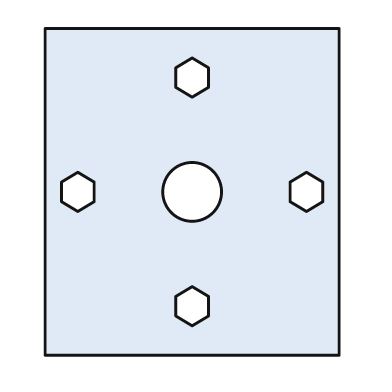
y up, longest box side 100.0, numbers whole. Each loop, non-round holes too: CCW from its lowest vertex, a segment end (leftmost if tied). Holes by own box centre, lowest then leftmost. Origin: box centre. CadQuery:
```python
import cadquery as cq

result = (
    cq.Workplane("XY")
    .moveTo(-45.0, -50.0)
    .lineTo(45.0, -50.0)
    .lineTo(45.0, 50.0)
    .lineTo(-45.0, 50.0)
    .close()
    .moveTo(0.0, -41.0)
    .lineTo(5.0, -38.0)
    .lineTo(5.0, -32.0)
    .lineTo(0.0, -29.0)
    .lineTo(-5.0, -32.0)
    .lineTo(-5.0, -38.0)
    .close()
    .moveTo(-35.0, -6.0)
    .lineTo(-30.0, -3.0)
    .lineTo(-30.0, 3.0)
    .lineTo(-35.0, 6.0)
    .lineTo(-40.0, 3.0)
    .lineTo(-40.0, -3.0)
    .close()
    .moveTo(0.0, 0.0)
    .circle(9.0)
    .moveTo(35.0, -6.0)
    .lineTo(40.0, -3.0)
    .lineTo(40.0, 3.0)
    .lineTo(35.0, 6.0)
    .lineTo(30.0, 3.0)
    .lineTo(30.0, -3.0)
    .close()
    .moveTo(0.0, 29.0)
    .lineTo(5.0, 32.0)
    .lineTo(5.0, 38.0)
    .lineTo(0.0, 41.0)
    .lineTo(-5.0, 38.0)
    .lineTo(-5.0, 32.0)
    .close()
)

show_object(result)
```